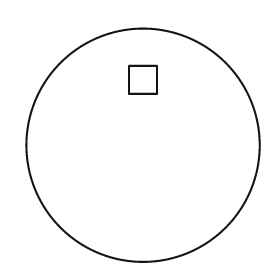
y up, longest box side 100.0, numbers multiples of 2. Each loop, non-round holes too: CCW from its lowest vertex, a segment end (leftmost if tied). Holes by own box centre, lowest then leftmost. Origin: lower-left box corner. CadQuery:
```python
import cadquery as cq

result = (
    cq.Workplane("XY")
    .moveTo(50.0, 50.0)
    .circle(50.0)
    .moveTo(44.0, 72.0)
    .lineTo(56.0, 72.0)
    .lineTo(56.0, 84.0)
    .lineTo(44.0, 84.0)
    .close()
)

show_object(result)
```